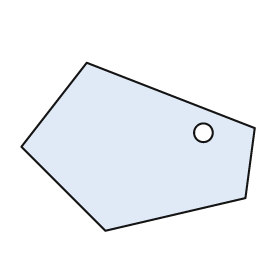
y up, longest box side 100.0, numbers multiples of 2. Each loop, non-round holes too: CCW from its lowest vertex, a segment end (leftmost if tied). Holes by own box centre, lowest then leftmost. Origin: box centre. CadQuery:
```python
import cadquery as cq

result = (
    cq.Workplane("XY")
    .moveTo(-14.0, -36.0)
    .lineTo(46.0, -22.0)
    .lineTo(50.0, 8.0)
    .lineTo(-22.0, 36.0)
    .lineTo(-50.0, 0.0)
    .close()
    .moveTo(28.0, 6.0)
    .circle(4.0)
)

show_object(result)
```